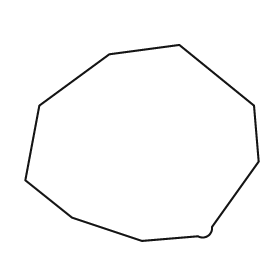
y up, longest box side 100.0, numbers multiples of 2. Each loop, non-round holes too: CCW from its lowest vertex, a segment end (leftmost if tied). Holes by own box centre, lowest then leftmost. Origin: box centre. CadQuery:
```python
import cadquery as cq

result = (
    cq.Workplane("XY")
    .moveTo(0.0, -42.0)
    .lineTo(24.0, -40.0)
    .threePointArc((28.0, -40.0), (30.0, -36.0))
    .lineTo(50.0, -8.0)
    .lineTo(48.0, 16.0)
    .lineTo(16.0, 42.0)
    .lineTo(-14.0, 38.0)
    .lineTo(-44.0, 16.0)
    .lineTo(-50.0, -16.0)
    .lineTo(-30.0, -32.0)
    .close()
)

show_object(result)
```